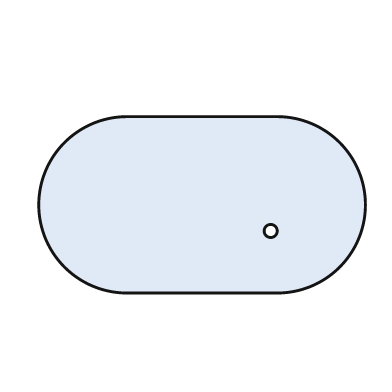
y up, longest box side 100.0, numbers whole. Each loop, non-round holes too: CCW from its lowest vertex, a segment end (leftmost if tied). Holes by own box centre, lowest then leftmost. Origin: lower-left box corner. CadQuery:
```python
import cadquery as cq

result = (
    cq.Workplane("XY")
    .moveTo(27.0, 0.0)
    .lineTo(73.0, 0.0)
    .threePointArc((100.0, 27.0), (73.0, 54.0))
    .lineTo(27.0, 54.0)
    .threePointArc((0.0, 27.0), (27.0, 0.0))
    .close()
    .moveTo(71.0, 19.0)
    .circle(2.0)
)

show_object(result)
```